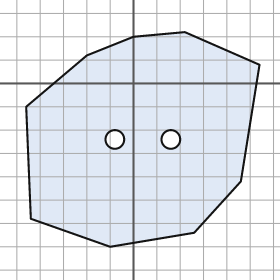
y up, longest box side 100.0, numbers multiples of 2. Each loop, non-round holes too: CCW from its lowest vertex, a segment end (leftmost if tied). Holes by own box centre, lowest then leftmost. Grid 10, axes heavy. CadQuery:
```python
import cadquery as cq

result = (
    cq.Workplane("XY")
    .moveTo(-10.0, -70.0)
    .lineTo(26.0, -64.0)
    .lineTo(46.0, -42.0)
    .lineTo(54.0, 8.0)
    .lineTo(22.0, 22.0)
    .lineTo(0.0, 20.0)
    .lineTo(-20.0, 12.0)
    .lineTo(-46.0, -10.0)
    .lineTo(-44.0, -58.0)
    .close()
    .moveTo(-8.0, -24.0)
    .circle(4.0)
    .moveTo(16.0, -24.0)
    .circle(4.0)
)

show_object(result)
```